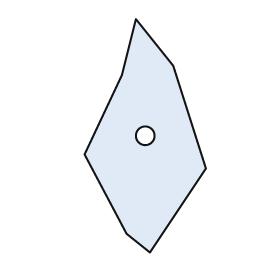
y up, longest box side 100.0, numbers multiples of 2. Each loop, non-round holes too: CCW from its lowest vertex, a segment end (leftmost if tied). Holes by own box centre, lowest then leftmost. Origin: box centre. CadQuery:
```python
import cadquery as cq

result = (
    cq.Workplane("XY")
    .moveTo(2.0, -50.0)
    .lineTo(26.0, -14.0)
    .lineTo(12.0, 30.0)
    .lineTo(-4.0, 50.0)
    .lineTo(-10.0, 26.0)
    .lineTo(-26.0, -8.0)
    .lineTo(-8.0, -42.0)
    .close()
    .moveTo(0.0, 0.0)
    .circle(4.0)
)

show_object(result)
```